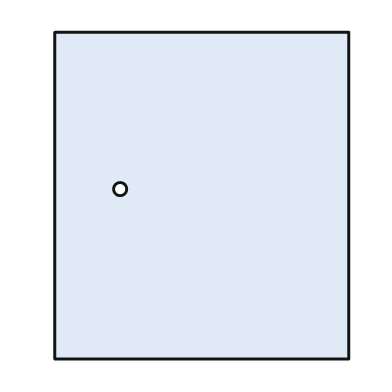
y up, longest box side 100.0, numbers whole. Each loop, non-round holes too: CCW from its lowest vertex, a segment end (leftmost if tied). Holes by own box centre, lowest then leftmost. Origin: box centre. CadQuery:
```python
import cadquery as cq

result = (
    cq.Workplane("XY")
    .moveTo(-45.0, -50.0)
    .lineTo(45.0, -50.0)
    .lineTo(45.0, 50.0)
    .lineTo(-45.0, 50.0)
    .close()
    .moveTo(-25.0, 2.0)
    .circle(2.0)
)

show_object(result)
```